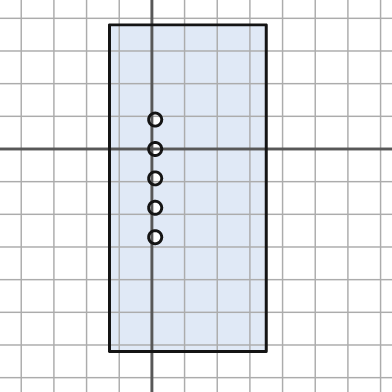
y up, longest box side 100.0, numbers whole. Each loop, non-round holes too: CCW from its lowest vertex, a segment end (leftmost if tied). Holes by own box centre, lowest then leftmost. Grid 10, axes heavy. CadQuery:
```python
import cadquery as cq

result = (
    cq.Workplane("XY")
    .moveTo(-13.0, -62.0)
    .lineTo(35.0, -62.0)
    .lineTo(35.0, 38.0)
    .lineTo(-13.0, 38.0)
    .close()
    .moveTo(1.0, -27.0)
    .circle(2.0)
    .moveTo(1.0, -18.0)
    .circle(2.0)
    .moveTo(1.0, -9.0)
    .circle(2.0)
    .moveTo(1.0, 0.0)
    .circle(2.0)
    .moveTo(1.0, 9.0)
    .circle(2.0)
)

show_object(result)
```